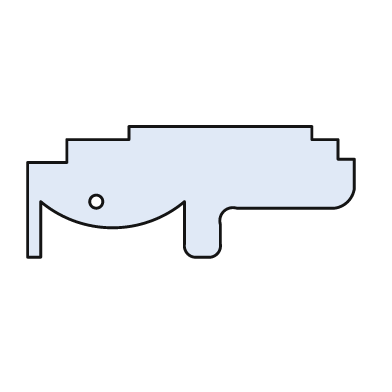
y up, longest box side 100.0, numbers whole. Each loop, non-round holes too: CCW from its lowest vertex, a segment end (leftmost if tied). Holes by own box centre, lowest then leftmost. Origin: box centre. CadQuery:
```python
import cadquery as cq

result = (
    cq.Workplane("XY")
    .moveTo(-50.0, -20.0)
    .lineTo(-46.0, -20.0)
    .lineTo(-46.0, -3.0)
    .threePointArc((-24.0, -11.0), (-2.0, -3.0))
    .lineTo(-2.0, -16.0)
    .threePointArc((-1.0, -19.0), (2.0, -20.0))
    .lineTo(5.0, -20.0)
    .threePointArc((8.0, -19.0), (9.0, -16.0))
    .lineTo(9.0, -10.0)
    .threePointArc((10.0, -6.0), (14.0, -5.0))
    .lineTo(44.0, -5.0)
    .threePointArc((48.0, -3.0), (50.0, 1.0))
    .lineTo(50.0, 10.0)
    .lineTo(45.0, 10.0)
    .lineTo(45.0, 16.0)
    .lineTo(37.0, 16.0)
    .lineTo(37.0, 20.0)
    .lineTo(-19.0, 20.0)
    .lineTo(-19.0, 16.0)
    .lineTo(-38.0, 16.0)
    .lineTo(-38.0, 9.0)
    .lineTo(-50.0, 9.0)
    .close()
    .moveTo(-29.0, -3.0)
    .circle(2.0)
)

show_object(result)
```